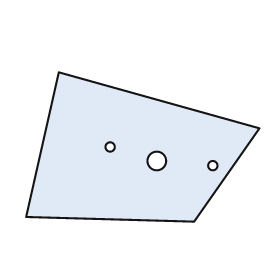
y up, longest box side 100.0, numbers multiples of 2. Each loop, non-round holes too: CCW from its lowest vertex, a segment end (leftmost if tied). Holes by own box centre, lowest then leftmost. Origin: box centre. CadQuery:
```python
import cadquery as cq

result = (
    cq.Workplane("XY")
    .moveTo(22.0, -32.0)
    .lineTo(50.0, 8.0)
    .lineTo(-36.0, 32.0)
    .lineTo(-50.0, -30.0)
    .close()
    .moveTo(30.0, -8.0)
    .circle(2.0)
    .moveTo(6.0, -6.0)
    .circle(4.0)
    .moveTo(-14.0, 0.0)
    .circle(2.0)
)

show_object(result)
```